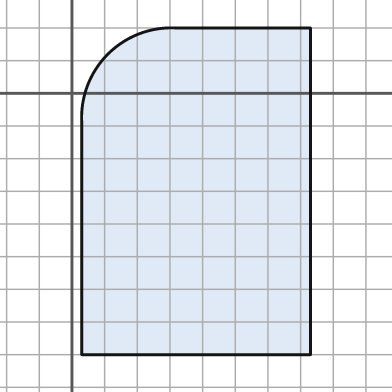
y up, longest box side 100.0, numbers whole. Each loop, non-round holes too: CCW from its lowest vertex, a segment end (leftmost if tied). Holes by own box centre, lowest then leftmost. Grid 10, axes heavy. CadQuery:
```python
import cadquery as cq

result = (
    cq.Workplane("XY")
    .moveTo(3.0, -80.0)
    .lineTo(73.0, -80.0)
    .lineTo(73.0, 20.0)
    .lineTo(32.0, 20.0)
    .threePointArc((11.0, 12.0), (3.0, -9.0))
    .close()
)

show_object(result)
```